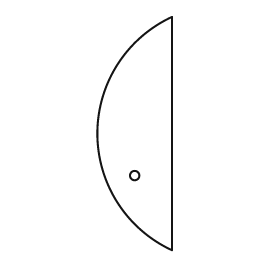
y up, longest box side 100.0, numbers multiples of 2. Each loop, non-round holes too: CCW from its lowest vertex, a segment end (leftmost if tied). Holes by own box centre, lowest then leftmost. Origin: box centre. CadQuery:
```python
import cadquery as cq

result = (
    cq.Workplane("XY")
    .moveTo(16.0, -50.0)
    .lineTo(16.0, 50.0)
    .threePointArc((-16.0, 0.0), (16.0, -50.0))
    .close()
    .moveTo(0.0, -18.0)
    .circle(2.0)
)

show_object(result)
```